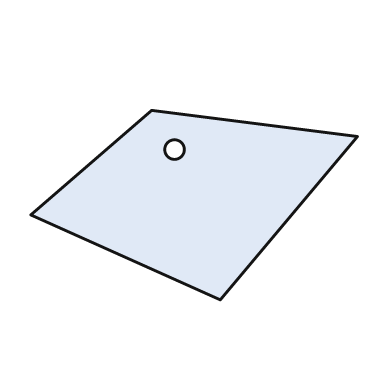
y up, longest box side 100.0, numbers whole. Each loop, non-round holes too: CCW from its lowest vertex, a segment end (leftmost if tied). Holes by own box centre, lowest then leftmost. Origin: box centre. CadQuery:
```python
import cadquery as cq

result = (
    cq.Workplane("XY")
    .moveTo(8.0, -29.0)
    .lineTo(50.0, 21.0)
    .lineTo(-13.0, 29.0)
    .lineTo(-50.0, -3.0)
    .close()
    .moveTo(-6.0, 17.0)
    .circle(3.0)
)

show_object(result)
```